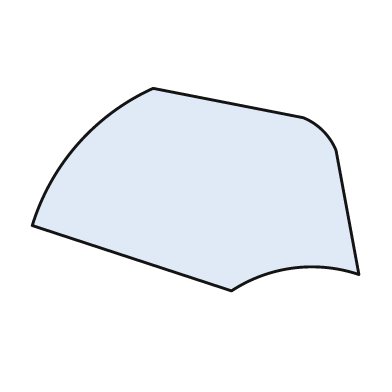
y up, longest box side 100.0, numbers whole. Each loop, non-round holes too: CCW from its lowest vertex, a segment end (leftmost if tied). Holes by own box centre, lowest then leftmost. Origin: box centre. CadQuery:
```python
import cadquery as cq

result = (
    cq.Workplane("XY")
    .moveTo(11.0, -31.0)
    .threePointArc((30.0, -24.0), (50.0, -26.0))
    .lineTo(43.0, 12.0)
    .threePointArc((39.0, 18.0), (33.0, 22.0))
    .lineTo(-13.0, 31.0)
    .threePointArc((-36.0, 14.0), (-50.0, -11.0))
    .close()
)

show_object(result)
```